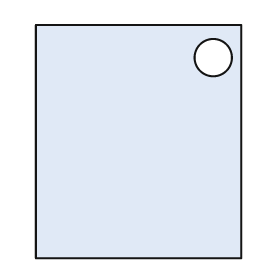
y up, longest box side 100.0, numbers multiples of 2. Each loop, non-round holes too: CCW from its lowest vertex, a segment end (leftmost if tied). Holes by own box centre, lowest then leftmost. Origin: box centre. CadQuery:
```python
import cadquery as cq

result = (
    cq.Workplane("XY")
    .moveTo(-44.0, -50.0)
    .lineTo(44.0, -50.0)
    .lineTo(44.0, 50.0)
    .lineTo(-44.0, 50.0)
    .close()
    .moveTo(32.0, 36.0)
    .circle(8.0)
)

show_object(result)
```